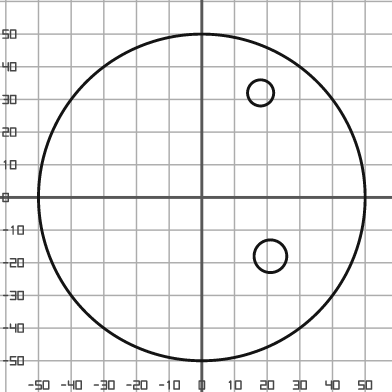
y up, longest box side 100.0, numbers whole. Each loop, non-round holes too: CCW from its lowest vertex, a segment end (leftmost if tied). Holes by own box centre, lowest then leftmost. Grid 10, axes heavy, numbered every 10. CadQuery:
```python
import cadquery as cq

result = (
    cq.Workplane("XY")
    .moveTo(0.0, 0.0)
    .circle(50.0)
    .moveTo(21.0, -18.0)
    .circle(5.0)
    .moveTo(18.0, 32.0)
    .circle(4.0)
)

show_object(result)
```